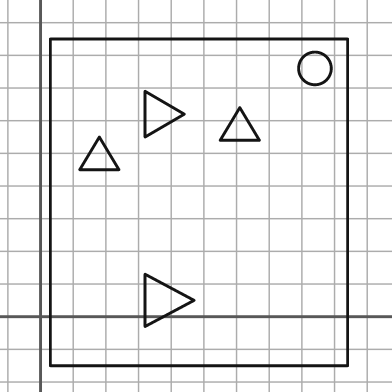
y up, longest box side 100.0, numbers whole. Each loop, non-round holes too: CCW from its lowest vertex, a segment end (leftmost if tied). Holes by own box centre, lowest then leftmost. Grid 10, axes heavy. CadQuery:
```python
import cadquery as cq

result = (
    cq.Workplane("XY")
    .moveTo(3.0, -15.0)
    .lineTo(94.0, -15.0)
    .lineTo(94.0, 85.0)
    .lineTo(3.0, 85.0)
    .close()
    .moveTo(32.0, -3.0)
    .lineTo(47.0, 5.0)
    .lineTo(32.0, 13.0)
    .close()
    .moveTo(12.0, 45.0)
    .lineTo(24.0, 45.0)
    .lineTo(18.0, 55.0)
    .close()
    .moveTo(55.0, 54.0)
    .lineTo(67.0, 54.0)
    .lineTo(61.0, 64.0)
    .close()
    .moveTo(32.0, 55.0)
    .lineTo(44.0, 62.0)
    .lineTo(32.0, 69.0)
    .close()
    .moveTo(84.0, 76.0)
    .circle(5.0)
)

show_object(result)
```